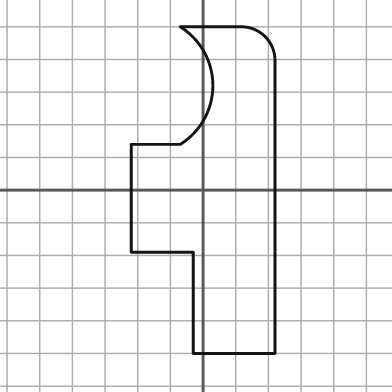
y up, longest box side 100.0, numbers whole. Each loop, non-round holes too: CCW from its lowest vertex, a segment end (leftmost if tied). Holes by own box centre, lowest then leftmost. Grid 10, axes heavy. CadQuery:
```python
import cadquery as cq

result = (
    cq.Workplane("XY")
    .moveTo(-3.0, -50.0)
    .lineTo(22.0, -50.0)
    .lineTo(22.0, 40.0)
    .threePointArc((19.0, 47.0), (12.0, 50.0))
    .lineTo(-7.0, 50.0)
    .threePointArc((3.0, 32.0), (-7.0, 14.0))
    .lineTo(-22.0, 14.0)
    .lineTo(-22.0, -19.0)
    .lineTo(-3.0, -19.0)
    .close()
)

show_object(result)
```